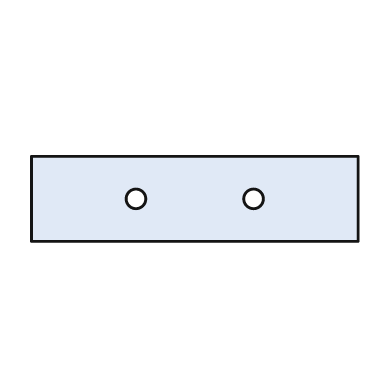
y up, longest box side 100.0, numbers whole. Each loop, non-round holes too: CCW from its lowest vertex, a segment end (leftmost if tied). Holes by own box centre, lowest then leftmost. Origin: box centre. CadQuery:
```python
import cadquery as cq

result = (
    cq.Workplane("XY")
    .moveTo(-50.0, -13.0)
    .lineTo(50.0, -13.0)
    .lineTo(50.0, 13.0)
    .lineTo(-50.0, 13.0)
    .close()
    .moveTo(-18.0, 0.0)
    .circle(3.0)
    .moveTo(18.0, 0.0)
    .circle(3.0)
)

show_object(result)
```